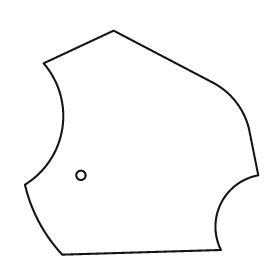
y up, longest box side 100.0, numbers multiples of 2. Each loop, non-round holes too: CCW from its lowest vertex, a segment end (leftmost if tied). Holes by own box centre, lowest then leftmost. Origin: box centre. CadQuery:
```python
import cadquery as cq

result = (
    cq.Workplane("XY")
    .moveTo(-34.0, -48.0)
    .lineTo(34.0, -46.0)
    .threePointArc((34.0, -26.0), (50.0, -14.0))
    .lineTo(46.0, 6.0)
    .threePointArc((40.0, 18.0), (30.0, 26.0))
    .lineTo(-12.0, 48.0)
    .lineTo(-42.0, 34.0)
    .threePointArc((-34.0, 6.0), (-50.0, -18.0))
    .threePointArc((-44.0, -34.0), (-34.0, -48.0))
    .close()
    .moveTo(-26.0, -14.0)
    .circle(2.0)
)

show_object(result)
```